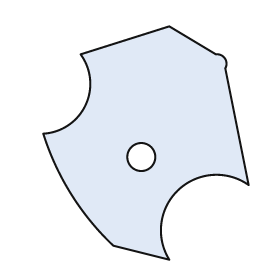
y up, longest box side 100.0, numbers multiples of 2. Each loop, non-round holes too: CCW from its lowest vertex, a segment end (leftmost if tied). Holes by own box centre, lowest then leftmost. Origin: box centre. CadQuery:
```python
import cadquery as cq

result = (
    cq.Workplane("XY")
    .moveTo(10.0, -50.0)
    .threePointArc((14.0, -20.0), (44.0, -18.0))
    .lineTo(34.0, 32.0)
    .threePointArc((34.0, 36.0), (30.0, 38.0))
    .lineTo(10.0, 50.0)
    .lineTo(-28.0, 38.0)
    .threePointArc((-26.0, 16.0), (-44.0, 4.0))
    .threePointArc((-32.0, -22.0), (-14.0, -44.0))
    .close()
    .moveTo(-2.0, -6.0)
    .circle(6.0)
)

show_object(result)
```